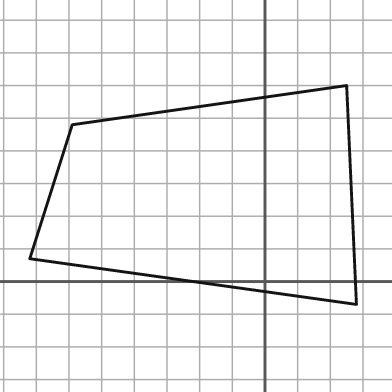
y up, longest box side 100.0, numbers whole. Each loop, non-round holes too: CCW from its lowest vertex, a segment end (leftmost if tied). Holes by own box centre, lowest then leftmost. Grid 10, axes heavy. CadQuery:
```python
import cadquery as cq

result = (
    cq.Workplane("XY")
    .moveTo(28.0, -7.0)
    .lineTo(25.0, 60.0)
    .lineTo(-59.0, 48.0)
    .lineTo(-72.0, 7.0)
    .close()
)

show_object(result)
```